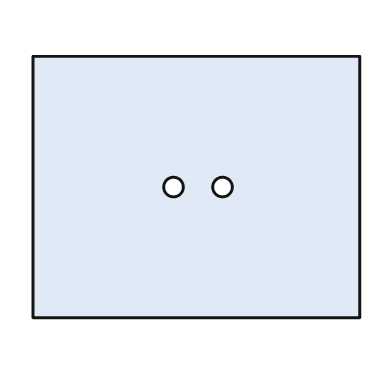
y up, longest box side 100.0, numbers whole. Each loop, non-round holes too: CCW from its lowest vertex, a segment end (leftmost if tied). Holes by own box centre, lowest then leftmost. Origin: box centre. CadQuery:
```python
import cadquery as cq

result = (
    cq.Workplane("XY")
    .moveTo(-50.0, -40.0)
    .lineTo(50.0, -40.0)
    .lineTo(50.0, 40.0)
    .lineTo(-50.0, 40.0)
    .close()
    .moveTo(-7.0, 0.0)
    .circle(3.0)
    .moveTo(8.0, 0.0)
    .circle(3.0)
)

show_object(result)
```